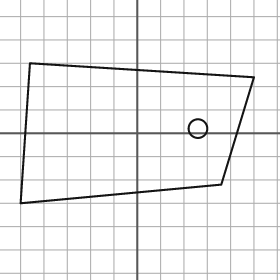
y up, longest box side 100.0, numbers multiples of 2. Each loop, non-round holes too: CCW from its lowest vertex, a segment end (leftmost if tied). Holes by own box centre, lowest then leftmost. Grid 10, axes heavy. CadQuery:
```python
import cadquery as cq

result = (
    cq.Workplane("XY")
    .moveTo(-50.0, -30.0)
    .lineTo(36.0, -22.0)
    .lineTo(50.0, 24.0)
    .lineTo(-46.0, 30.0)
    .close()
    .moveTo(26.0, 2.0)
    .circle(4.0)
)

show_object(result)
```